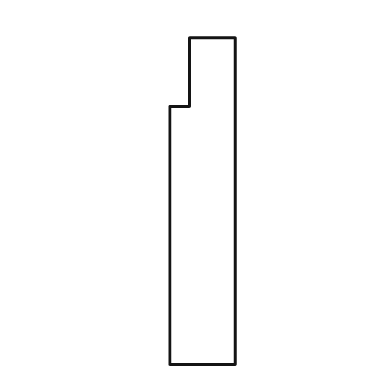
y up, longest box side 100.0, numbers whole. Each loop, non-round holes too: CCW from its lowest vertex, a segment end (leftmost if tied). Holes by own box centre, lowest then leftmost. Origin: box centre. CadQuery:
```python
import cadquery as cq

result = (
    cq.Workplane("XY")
    .moveTo(-10.0, -50.0)
    .lineTo(10.0, -50.0)
    .lineTo(10.0, 50.0)
    .lineTo(-4.0, 50.0)
    .lineTo(-4.0, 29.0)
    .lineTo(-10.0, 29.0)
    .close()
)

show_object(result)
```